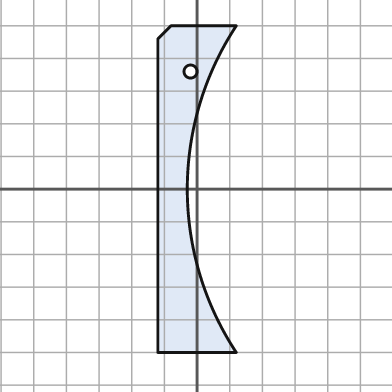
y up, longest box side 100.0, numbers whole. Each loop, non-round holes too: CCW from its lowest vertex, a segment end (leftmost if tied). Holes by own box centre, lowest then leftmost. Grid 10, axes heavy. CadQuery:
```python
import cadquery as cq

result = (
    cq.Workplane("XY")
    .moveTo(-12.0, -50.0)
    .lineTo(12.0, -50.0)
    .threePointArc((-3.0, 0.0), (12.0, 50.0))
    .lineTo(-8.0, 50.0)
    .lineTo(-12.0, 46.0)
    .close()
    .moveTo(-2.0, 36.0)
    .circle(2.0)
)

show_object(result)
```